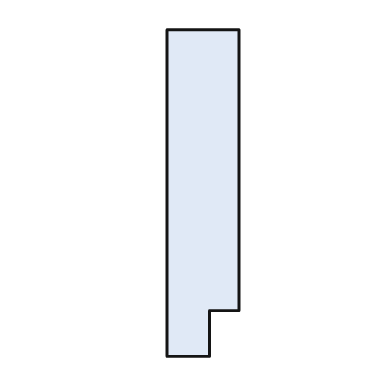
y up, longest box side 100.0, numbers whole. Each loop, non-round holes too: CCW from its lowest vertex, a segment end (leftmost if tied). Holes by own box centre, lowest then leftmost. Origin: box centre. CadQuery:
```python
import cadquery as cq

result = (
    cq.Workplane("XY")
    .moveTo(-11.0, -50.0)
    .lineTo(2.0, -50.0)
    .lineTo(2.0, -36.0)
    .lineTo(11.0, -36.0)
    .lineTo(11.0, 50.0)
    .lineTo(-11.0, 50.0)
    .close()
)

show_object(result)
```